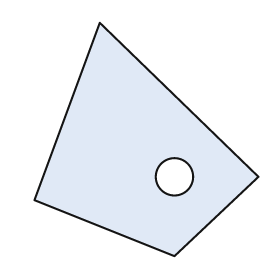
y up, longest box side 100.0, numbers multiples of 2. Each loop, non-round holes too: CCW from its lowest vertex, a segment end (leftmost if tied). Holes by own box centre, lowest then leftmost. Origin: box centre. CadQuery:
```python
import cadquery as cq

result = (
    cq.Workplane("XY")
    .moveTo(12.0, -50.0)
    .lineTo(48.0, -16.0)
    .lineTo(-20.0, 50.0)
    .lineTo(-48.0, -26.0)
    .close()
    .moveTo(12.0, -16.0)
    .circle(8.0)
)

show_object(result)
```